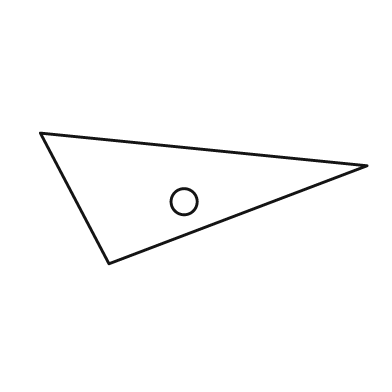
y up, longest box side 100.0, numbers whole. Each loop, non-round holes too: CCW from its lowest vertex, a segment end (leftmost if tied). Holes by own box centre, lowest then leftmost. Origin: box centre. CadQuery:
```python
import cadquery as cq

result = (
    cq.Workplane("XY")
    .moveTo(-29.0, -20.0)
    .lineTo(50.0, 10.0)
    .lineTo(-50.0, 20.0)
    .close()
    .moveTo(-6.0, -1.0)
    .circle(4.0)
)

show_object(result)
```